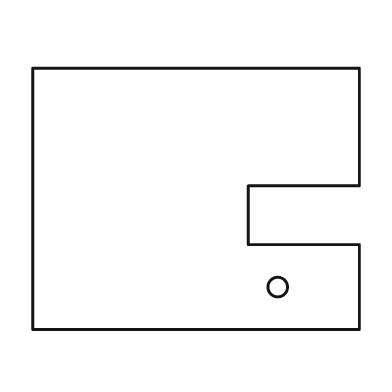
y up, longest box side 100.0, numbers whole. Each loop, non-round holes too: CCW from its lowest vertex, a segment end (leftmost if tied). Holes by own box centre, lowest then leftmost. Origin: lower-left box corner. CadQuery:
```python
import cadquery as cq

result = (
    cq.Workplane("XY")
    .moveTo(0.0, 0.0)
    .lineTo(100.0, 0.0)
    .lineTo(100.0, 26.0)
    .lineTo(66.0, 26.0)
    .lineTo(66.0, 44.0)
    .lineTo(100.0, 44.0)
    .lineTo(100.0, 80.0)
    .lineTo(0.0, 80.0)
    .close()
    .moveTo(75.0, 13.0)
    .circle(3.0)
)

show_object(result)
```